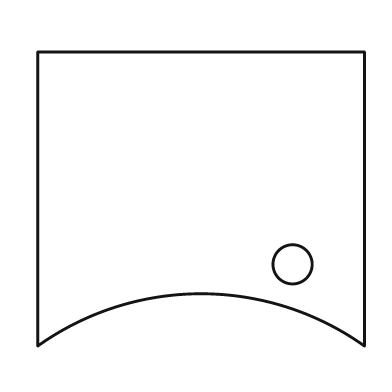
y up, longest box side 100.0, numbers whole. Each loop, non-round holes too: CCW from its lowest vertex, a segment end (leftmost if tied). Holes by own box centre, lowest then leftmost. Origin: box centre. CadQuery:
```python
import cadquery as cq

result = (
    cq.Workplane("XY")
    .moveTo(-50.0, -45.0)
    .threePointArc((0.0, -29.0), (50.0, -45.0))
    .lineTo(50.0, 45.0)
    .lineTo(-50.0, 45.0)
    .close()
    .moveTo(28.0, -20.0)
    .circle(6.0)
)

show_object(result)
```